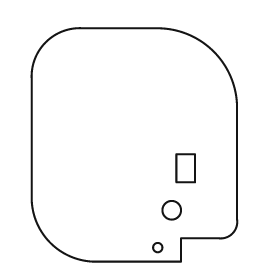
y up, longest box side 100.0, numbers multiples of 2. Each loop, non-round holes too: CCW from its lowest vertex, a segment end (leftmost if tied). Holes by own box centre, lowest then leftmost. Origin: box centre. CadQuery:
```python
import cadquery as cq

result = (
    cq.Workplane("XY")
    .moveTo(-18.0, -50.0)
    .lineTo(20.0, -50.0)
    .lineTo(20.0, -40.0)
    .lineTo(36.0, -40.0)
    .threePointArc((42.0, -38.0), (44.0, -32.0))
    .lineTo(44.0, 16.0)
    .threePointArc((34.0, 40.0), (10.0, 50.0))
    .lineTo(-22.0, 50.0)
    .threePointArc((-38.0, 44.0), (-44.0, 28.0))
    .lineTo(-44.0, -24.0)
    .threePointArc((-36.0, -42.0), (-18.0, -50.0))
    .close()
    .moveTo(10.0, -44.0)
    .circle(2.0)
    .moveTo(16.0, -28.0)
    .circle(4.0)
    .moveTo(18.0, -16.0)
    .lineTo(26.0, -16.0)
    .lineTo(26.0, -4.0)
    .lineTo(18.0, -4.0)
    .close()
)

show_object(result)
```